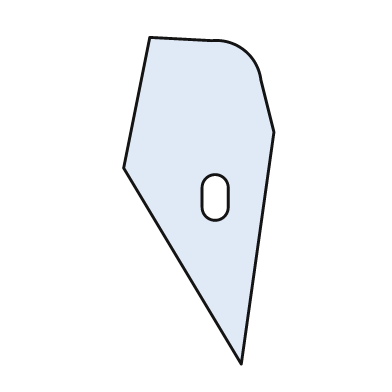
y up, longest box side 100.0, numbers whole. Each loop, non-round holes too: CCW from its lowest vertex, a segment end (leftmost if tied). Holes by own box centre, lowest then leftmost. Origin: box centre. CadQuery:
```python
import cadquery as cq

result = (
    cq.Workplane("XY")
    .moveTo(13.0, -50.0)
    .lineTo(23.0, 21.0)
    .lineTo(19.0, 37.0)
    .threePointArc((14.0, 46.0), (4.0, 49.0))
    .lineTo(-15.0, 50.0)
    .lineTo(-23.0, 10.0)
    .close()
    .moveTo(1.0, -2.0)
    .threePointArc((5.0, -6.0), (9.0, -2.0))
    .lineTo(9.0, 4.0)
    .threePointArc((5.0, 8.0), (1.0, 4.0))
    .close()
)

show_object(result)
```